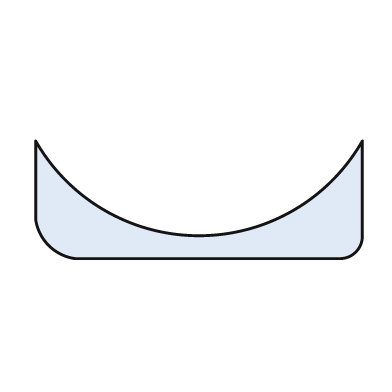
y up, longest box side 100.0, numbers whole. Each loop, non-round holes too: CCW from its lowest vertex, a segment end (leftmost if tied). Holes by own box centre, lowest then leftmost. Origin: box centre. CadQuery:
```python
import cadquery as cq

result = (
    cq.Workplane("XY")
    .moveTo(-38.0, -18.0)
    .lineTo(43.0, -18.0)
    .threePointArc((48.0, -16.0), (50.0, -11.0))
    .lineTo(50.0, 18.0)
    .threePointArc((0.0, -11.0), (-50.0, 18.0))
    .lineTo(-50.0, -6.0)
    .threePointArc((-46.0, -14.0), (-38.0, -18.0))
    .close()
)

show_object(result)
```